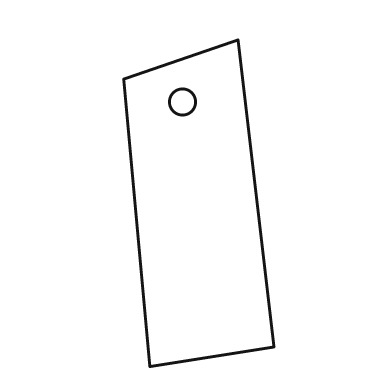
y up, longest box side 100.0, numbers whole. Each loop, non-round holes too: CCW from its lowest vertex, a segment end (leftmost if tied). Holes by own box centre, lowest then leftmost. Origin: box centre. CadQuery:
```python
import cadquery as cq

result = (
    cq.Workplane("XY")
    .moveTo(-15.0, -50.0)
    .lineTo(23.0, -44.0)
    .lineTo(12.0, 50.0)
    .lineTo(-23.0, 38.0)
    .close()
    .moveTo(-5.0, 31.0)
    .circle(4.0)
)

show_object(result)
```